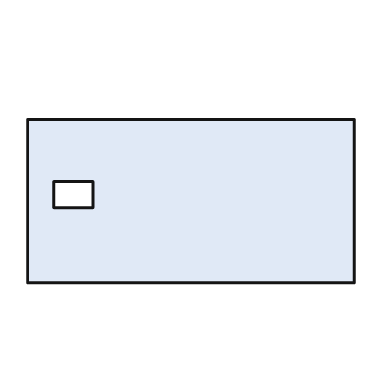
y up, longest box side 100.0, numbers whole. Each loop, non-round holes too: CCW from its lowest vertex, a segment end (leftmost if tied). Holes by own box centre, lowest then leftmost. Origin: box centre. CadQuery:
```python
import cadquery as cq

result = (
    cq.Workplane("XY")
    .moveTo(-50.0, -25.0)
    .lineTo(50.0, -25.0)
    .lineTo(50.0, 25.0)
    .lineTo(-50.0, 25.0)
    .close()
    .moveTo(-42.0, -2.0)
    .lineTo(-30.0, -2.0)
    .lineTo(-30.0, 6.0)
    .lineTo(-42.0, 6.0)
    .close()
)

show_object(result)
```